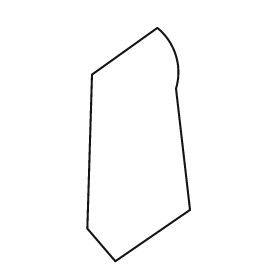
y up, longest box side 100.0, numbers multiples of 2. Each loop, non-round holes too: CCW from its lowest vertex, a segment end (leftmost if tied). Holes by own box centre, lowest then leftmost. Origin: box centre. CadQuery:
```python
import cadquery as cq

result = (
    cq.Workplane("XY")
    .moveTo(-10.0, -50.0)
    .lineTo(22.0, -28.0)
    .lineTo(16.0, 24.0)
    .threePointArc((16.0, 38.0), (8.0, 50.0))
    .lineTo(-20.0, 30.0)
    .lineTo(-22.0, -36.0)
    .close()
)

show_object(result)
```